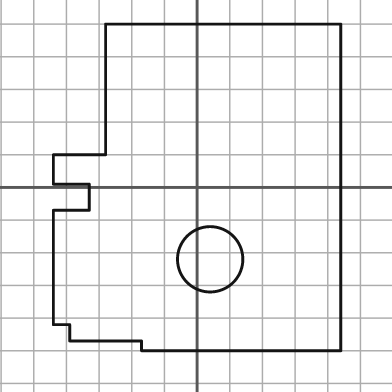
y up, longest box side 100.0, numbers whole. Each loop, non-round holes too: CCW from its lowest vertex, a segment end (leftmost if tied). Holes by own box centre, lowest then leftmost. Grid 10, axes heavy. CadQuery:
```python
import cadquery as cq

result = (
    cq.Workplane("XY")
    .moveTo(-17.0, -50.0)
    .lineTo(44.0, -50.0)
    .lineTo(44.0, 50.0)
    .lineTo(-28.0, 50.0)
    .lineTo(-28.0, 10.0)
    .lineTo(-44.0, 10.0)
    .lineTo(-44.0, 1.0)
    .lineTo(-33.0, 1.0)
    .lineTo(-33.0, -7.0)
    .lineTo(-44.0, -7.0)
    .lineTo(-44.0, -42.0)
    .lineTo(-39.0, -42.0)
    .lineTo(-39.0, -47.0)
    .lineTo(-17.0, -47.0)
    .close()
    .moveTo(4.0, -22.0)
    .circle(10.0)
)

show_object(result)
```